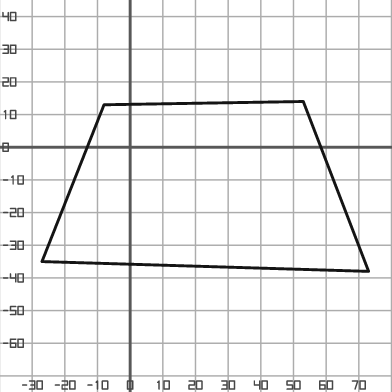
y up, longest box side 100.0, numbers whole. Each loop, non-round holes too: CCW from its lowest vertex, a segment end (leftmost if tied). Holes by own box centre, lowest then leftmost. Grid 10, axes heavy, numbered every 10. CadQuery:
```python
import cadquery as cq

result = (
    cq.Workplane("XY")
    .moveTo(73.0, -38.0)
    .lineTo(53.0, 14.0)
    .lineTo(-8.0, 13.0)
    .lineTo(-27.0, -35.0)
    .close()
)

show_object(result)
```